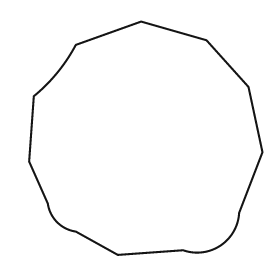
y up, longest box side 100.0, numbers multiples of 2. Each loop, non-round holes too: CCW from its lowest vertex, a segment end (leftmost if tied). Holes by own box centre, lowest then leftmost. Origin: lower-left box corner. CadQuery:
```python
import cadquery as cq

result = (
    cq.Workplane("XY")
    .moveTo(38.0, 0.0)
    .lineTo(66.0, 2.0)
    .threePointArc((82.0, 4.0), (90.0, 18.0))
    .lineTo(100.0, 44.0)
    .lineTo(94.0, 72.0)
    .lineTo(76.0, 92.0)
    .lineTo(48.0, 100.0)
    .lineTo(20.0, 90.0)
    .threePointArc((12.0, 78.0), (2.0, 68.0))
    .lineTo(0.0, 40.0)
    .lineTo(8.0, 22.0)
    .threePointArc((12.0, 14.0), (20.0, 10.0))
    .close()
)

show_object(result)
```